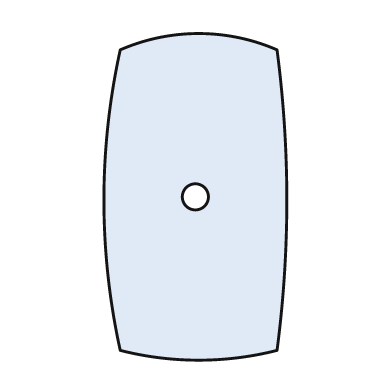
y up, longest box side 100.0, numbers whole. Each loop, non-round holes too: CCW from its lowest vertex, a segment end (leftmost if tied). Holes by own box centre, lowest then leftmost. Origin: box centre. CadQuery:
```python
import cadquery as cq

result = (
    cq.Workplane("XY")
    .moveTo(-23.0, -47.0)
    .threePointArc((1.0, -50.0), (25.0, -47.0))
    .threePointArc((28.0, -1.0), (25.0, 45.0))
    .threePointArc((1.0, 50.0), (-23.0, 45.0))
    .threePointArc((-28.0, -1.0), (-23.0, -47.0))
    .close()
    .moveTo(0.0, 0.0)
    .circle(4.0)
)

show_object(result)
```